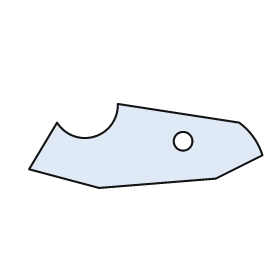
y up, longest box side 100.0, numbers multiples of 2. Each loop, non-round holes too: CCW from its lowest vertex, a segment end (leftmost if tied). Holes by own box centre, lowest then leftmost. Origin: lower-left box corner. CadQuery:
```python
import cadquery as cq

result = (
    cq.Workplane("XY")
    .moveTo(30.0, 0.0)
    .lineTo(80.0, 4.0)
    .lineTo(100.0, 14.0)
    .threePointArc((96.0, 22.0), (90.0, 28.0))
    .lineTo(38.0, 36.0)
    .threePointArc((28.0, 22.0), (12.0, 28.0))
    .lineTo(0.0, 8.0)
    .close()
    .moveTo(66.0, 20.0)
    .circle(4.0)
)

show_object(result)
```